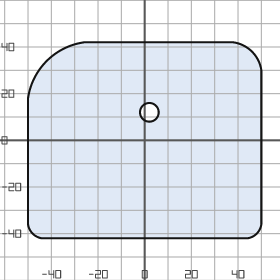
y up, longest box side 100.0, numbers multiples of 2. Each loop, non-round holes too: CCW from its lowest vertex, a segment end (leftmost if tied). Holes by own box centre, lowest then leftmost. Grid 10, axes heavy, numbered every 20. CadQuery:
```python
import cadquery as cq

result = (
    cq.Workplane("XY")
    .moveTo(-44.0, -42.0)
    .lineTo(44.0, -42.0)
    .threePointArc((48.0, -40.0), (50.0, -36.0))
    .lineTo(50.0, 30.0)
    .threePointArc((46.0, 38.0), (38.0, 42.0))
    .lineTo(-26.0, 42.0)
    .threePointArc((-42.0, 34.0), (-50.0, 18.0))
    .lineTo(-50.0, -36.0)
    .threePointArc((-48.0, -40.0), (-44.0, -42.0))
    .close()
    .moveTo(2.0, 12.0)
    .circle(4.0)
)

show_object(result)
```